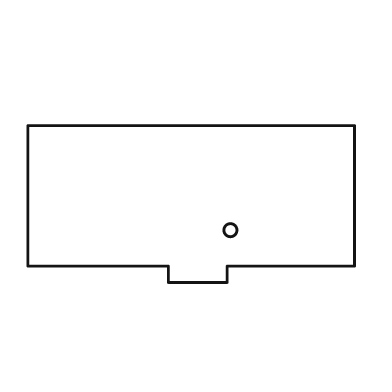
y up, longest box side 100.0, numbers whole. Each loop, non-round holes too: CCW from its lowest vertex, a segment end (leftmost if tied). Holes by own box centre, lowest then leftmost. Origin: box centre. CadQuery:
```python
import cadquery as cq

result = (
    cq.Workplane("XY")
    .moveTo(-7.0, -24.0)
    .lineTo(11.0, -24.0)
    .lineTo(11.0, -19.0)
    .lineTo(50.0, -19.0)
    .lineTo(50.0, 24.0)
    .lineTo(-50.0, 24.0)
    .lineTo(-50.0, -19.0)
    .lineTo(-7.0, -19.0)
    .close()
    .moveTo(12.0, -8.0)
    .circle(2.0)
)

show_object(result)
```